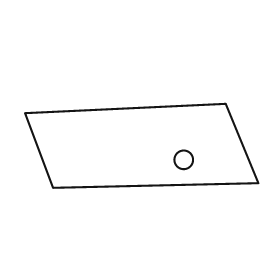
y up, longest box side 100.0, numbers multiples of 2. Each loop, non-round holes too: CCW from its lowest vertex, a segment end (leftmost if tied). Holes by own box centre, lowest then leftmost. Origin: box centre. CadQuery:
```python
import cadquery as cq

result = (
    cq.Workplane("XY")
    .moveTo(-38.0, -18.0)
    .lineTo(50.0, -16.0)
    .lineTo(36.0, 18.0)
    .lineTo(-50.0, 14.0)
    .close()
    .moveTo(18.0, -6.0)
    .circle(4.0)
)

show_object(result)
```